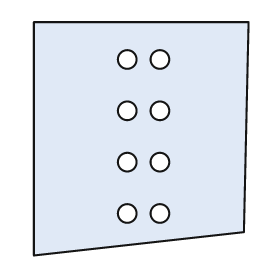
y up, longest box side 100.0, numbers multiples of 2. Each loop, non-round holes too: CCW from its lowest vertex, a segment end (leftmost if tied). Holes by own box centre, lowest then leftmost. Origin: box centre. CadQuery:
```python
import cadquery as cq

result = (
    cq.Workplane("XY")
    .moveTo(-46.0, -50.0)
    .lineTo(44.0, -40.0)
    .lineTo(46.0, 50.0)
    .lineTo(-46.0, 50.0)
    .close()
    .moveTo(-6.0, -32.0)
    .circle(4.0)
    .moveTo(8.0, -32.0)
    .circle(4.0)
    .moveTo(-6.0, -10.0)
    .circle(4.0)
    .moveTo(8.0, -10.0)
    .circle(4.0)
    .moveTo(-6.0, 12.0)
    .circle(4.0)
    .moveTo(8.0, 12.0)
    .circle(4.0)
    .moveTo(-6.0, 34.0)
    .circle(4.0)
    .moveTo(8.0, 34.0)
    .circle(4.0)
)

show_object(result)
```